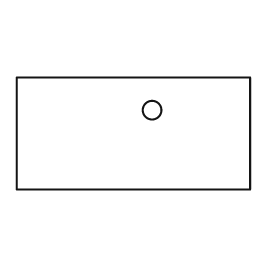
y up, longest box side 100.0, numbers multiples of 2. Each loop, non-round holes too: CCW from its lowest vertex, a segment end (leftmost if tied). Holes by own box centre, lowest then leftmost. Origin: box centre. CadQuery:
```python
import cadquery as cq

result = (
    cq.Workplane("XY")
    .moveTo(-50.0, -24.0)
    .lineTo(50.0, -24.0)
    .lineTo(50.0, 24.0)
    .lineTo(-50.0, 24.0)
    .close()
    .moveTo(8.0, 10.0)
    .circle(4.0)
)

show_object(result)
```